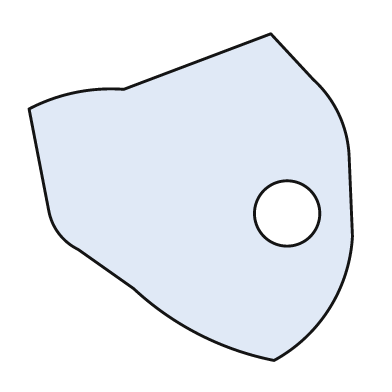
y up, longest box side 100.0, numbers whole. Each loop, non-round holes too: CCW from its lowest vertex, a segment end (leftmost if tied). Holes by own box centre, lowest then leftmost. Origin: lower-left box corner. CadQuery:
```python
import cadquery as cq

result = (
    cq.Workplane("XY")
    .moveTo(75.0, 0.0)
    .threePointArc((92.0, 16.0), (99.0, 38.0))
    .lineTo(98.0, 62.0)
    .threePointArc((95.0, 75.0), (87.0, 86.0))
    .lineTo(74.0, 100.0)
    .lineTo(29.0, 83.0)
    .threePointArc((14.0, 82.0), (0.0, 77.0))
    .lineTo(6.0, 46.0)
    .threePointArc((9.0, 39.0), (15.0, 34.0))
    .lineTo(32.0, 22.0)
    .threePointArc((52.0, 8.0), (75.0, 0.0))
    .close()
    .moveTo(79.0, 45.0)
    .circle(10.0)
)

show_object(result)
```